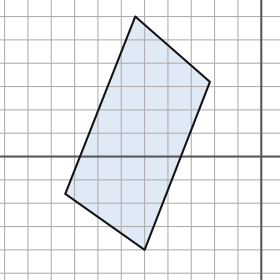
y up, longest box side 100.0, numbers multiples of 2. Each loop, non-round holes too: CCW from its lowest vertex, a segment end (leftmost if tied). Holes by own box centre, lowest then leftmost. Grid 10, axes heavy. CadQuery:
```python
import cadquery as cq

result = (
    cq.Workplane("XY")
    .moveTo(-50.0, -40.0)
    .lineTo(-22.0, 32.0)
    .lineTo(-54.0, 60.0)
    .lineTo(-84.0, -16.0)
    .close()
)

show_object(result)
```